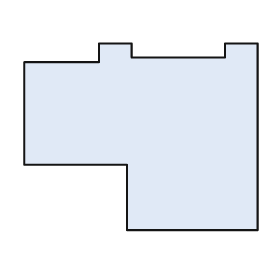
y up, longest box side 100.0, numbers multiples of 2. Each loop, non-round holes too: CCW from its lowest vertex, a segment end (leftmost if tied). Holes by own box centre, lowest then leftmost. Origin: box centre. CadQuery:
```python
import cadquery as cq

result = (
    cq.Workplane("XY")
    .moveTo(-6.0, -40.0)
    .lineTo(50.0, -40.0)
    .lineTo(50.0, 40.0)
    .lineTo(36.0, 40.0)
    .lineTo(36.0, 34.0)
    .lineTo(-4.0, 34.0)
    .lineTo(-4.0, 40.0)
    .lineTo(-18.0, 40.0)
    .lineTo(-18.0, 32.0)
    .lineTo(-50.0, 32.0)
    .lineTo(-50.0, -12.0)
    .lineTo(-6.0, -12.0)
    .close()
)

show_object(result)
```